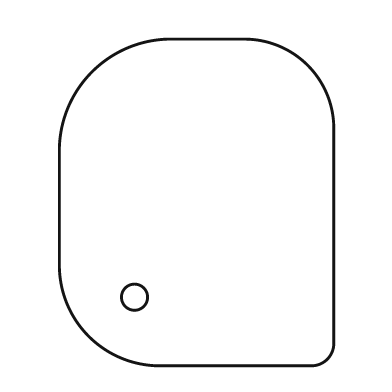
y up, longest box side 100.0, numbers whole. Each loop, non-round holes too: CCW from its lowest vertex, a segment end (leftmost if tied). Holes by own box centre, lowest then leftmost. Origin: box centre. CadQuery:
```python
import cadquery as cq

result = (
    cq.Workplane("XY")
    .moveTo(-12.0, -50.0)
    .lineTo(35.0, -50.0)
    .threePointArc((40.0, -48.0), (42.0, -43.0))
    .lineTo(42.0, 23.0)
    .threePointArc((34.0, 42.0), (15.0, 50.0))
    .lineTo(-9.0, 50.0)
    .threePointArc((-32.0, 40.0), (-42.0, 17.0))
    .lineTo(-42.0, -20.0)
    .threePointArc((-33.0, -41.0), (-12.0, -50.0))
    .close()
    .moveTo(-19.0, -29.0)
    .circle(4.0)
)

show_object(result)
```